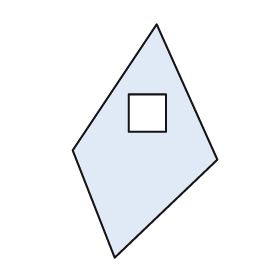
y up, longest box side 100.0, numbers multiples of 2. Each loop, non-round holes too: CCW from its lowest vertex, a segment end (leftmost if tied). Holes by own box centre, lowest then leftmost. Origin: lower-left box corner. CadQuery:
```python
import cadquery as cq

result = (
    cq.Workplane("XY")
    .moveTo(18.0, 0.0)
    .lineTo(62.0, 42.0)
    .lineTo(36.0, 100.0)
    .lineTo(0.0, 46.0)
    .close()
    .moveTo(24.0, 54.0)
    .lineTo(40.0, 54.0)
    .lineTo(40.0, 70.0)
    .lineTo(24.0, 70.0)
    .close()
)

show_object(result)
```